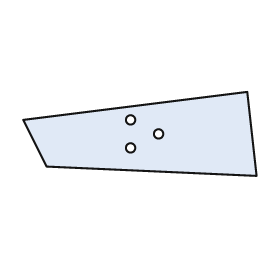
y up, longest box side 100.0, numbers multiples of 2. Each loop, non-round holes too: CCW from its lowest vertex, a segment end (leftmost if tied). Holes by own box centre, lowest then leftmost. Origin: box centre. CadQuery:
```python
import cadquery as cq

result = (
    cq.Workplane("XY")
    .moveTo(50.0, -18.0)
    .lineTo(46.0, 18.0)
    .lineTo(-50.0, 6.0)
    .lineTo(-40.0, -14.0)
    .close()
    .moveTo(-4.0, -6.0)
    .circle(2.0)
    .moveTo(8.0, 0.0)
    .circle(2.0)
    .moveTo(-4.0, 6.0)
    .circle(2.0)
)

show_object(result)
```